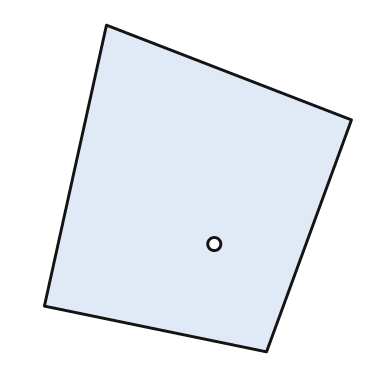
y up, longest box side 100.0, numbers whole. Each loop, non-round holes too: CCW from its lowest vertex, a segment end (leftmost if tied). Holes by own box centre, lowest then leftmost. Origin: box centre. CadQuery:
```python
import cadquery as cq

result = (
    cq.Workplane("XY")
    .moveTo(21.0, -50.0)
    .lineTo(47.0, 21.0)
    .lineTo(-28.0, 50.0)
    .lineTo(-47.0, -36.0)
    .close()
    .moveTo(5.0, -17.0)
    .circle(2.0)
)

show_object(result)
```